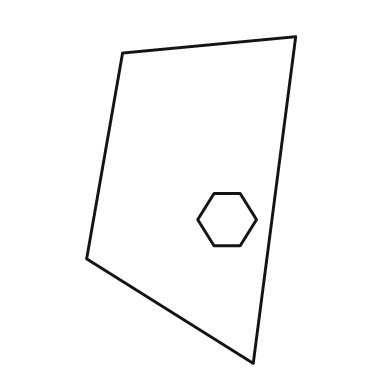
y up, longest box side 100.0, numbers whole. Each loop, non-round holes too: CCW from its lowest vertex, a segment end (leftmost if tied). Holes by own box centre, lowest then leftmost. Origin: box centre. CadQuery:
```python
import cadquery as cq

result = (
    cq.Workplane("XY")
    .moveTo(19.0, -50.0)
    .lineTo(32.0, 50.0)
    .lineTo(-21.0, 45.0)
    .lineTo(-32.0, -18.0)
    .close()
    .moveTo(7.0, -14.0)
    .lineTo(15.0, -14.0)
    .lineTo(20.0, -6.0)
    .lineTo(15.0, 2.0)
    .lineTo(7.0, 2.0)
    .lineTo(2.0, -6.0)
    .close()
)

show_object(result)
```